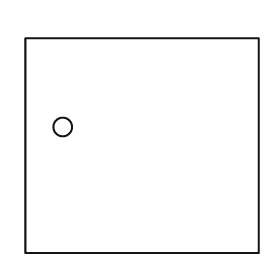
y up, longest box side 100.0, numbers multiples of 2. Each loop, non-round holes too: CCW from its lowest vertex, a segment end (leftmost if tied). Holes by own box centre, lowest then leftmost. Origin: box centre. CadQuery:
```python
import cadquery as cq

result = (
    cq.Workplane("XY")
    .moveTo(-50.0, -46.0)
    .lineTo(50.0, -46.0)
    .lineTo(50.0, 46.0)
    .lineTo(-50.0, 46.0)
    .close()
    .moveTo(-34.0, 8.0)
    .circle(4.0)
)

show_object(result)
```